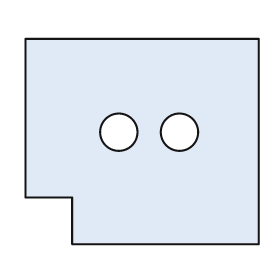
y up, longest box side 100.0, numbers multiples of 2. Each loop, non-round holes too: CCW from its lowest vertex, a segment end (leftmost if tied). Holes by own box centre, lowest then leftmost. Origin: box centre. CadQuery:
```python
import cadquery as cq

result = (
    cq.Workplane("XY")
    .moveTo(-30.0, -44.0)
    .lineTo(50.0, -44.0)
    .lineTo(50.0, 44.0)
    .lineTo(-50.0, 44.0)
    .lineTo(-50.0, -24.0)
    .lineTo(-30.0, -24.0)
    .close()
    .moveTo(-10.0, 4.0)
    .circle(8.0)
    .moveTo(16.0, 4.0)
    .circle(8.0)
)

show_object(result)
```